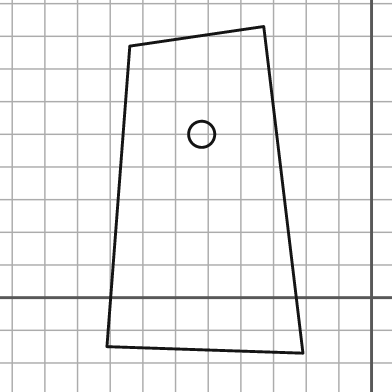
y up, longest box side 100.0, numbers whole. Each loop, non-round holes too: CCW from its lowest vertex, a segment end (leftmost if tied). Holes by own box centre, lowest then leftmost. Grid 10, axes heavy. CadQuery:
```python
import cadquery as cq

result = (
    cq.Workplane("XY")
    .moveTo(-21.0, -17.0)
    .lineTo(-33.0, 83.0)
    .lineTo(-74.0, 77.0)
    .lineTo(-81.0, -15.0)
    .close()
    .moveTo(-52.0, 50.0)
    .circle(4.0)
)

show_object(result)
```